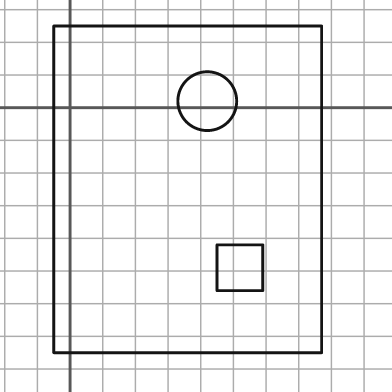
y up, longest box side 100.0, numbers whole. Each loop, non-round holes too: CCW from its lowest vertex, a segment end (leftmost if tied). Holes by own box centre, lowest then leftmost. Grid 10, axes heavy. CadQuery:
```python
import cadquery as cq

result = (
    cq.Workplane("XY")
    .moveTo(-5.0, -75.0)
    .lineTo(77.0, -75.0)
    .lineTo(77.0, 25.0)
    .lineTo(-5.0, 25.0)
    .close()
    .moveTo(45.0, -56.0)
    .lineTo(59.0, -56.0)
    .lineTo(59.0, -42.0)
    .lineTo(45.0, -42.0)
    .close()
    .moveTo(42.0, 2.0)
    .circle(9.0)
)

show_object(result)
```